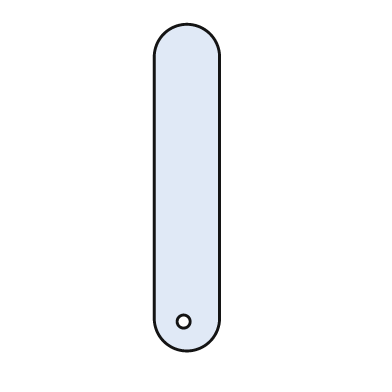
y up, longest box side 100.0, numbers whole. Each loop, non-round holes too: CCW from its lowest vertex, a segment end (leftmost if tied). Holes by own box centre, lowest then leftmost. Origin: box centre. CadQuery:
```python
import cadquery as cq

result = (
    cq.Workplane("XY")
    .moveTo(-10.0, -40.0)
    .threePointArc((0.0, -50.0), (10.0, -40.0))
    .lineTo(10.0, 40.0)
    .threePointArc((0.0, 50.0), (-10.0, 40.0))
    .close()
    .moveTo(-1.0, -41.0)
    .circle(2.0)
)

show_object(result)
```